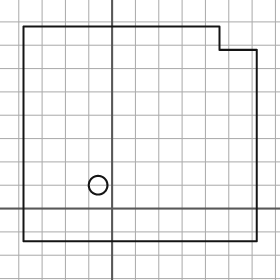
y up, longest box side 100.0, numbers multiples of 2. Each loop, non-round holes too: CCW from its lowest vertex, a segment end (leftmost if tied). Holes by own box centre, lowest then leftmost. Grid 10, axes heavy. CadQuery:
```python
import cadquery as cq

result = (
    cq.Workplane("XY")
    .moveTo(-38.0, -14.0)
    .lineTo(62.0, -14.0)
    .lineTo(62.0, 68.0)
    .lineTo(46.0, 68.0)
    .lineTo(46.0, 78.0)
    .lineTo(-38.0, 78.0)
    .close()
    .moveTo(-6.0, 10.0)
    .circle(4.0)
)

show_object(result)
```